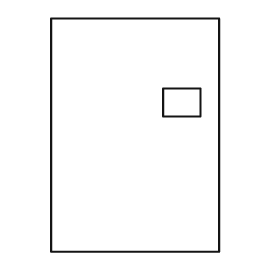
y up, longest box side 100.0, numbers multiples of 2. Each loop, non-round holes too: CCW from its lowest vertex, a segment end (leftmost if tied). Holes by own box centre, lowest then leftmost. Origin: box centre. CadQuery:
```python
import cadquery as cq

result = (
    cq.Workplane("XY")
    .moveTo(-36.0, -50.0)
    .lineTo(36.0, -50.0)
    .lineTo(36.0, 50.0)
    .lineTo(-36.0, 50.0)
    .close()
    .moveTo(12.0, 8.0)
    .lineTo(28.0, 8.0)
    .lineTo(28.0, 20.0)
    .lineTo(12.0, 20.0)
    .close()
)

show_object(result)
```